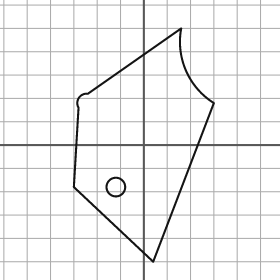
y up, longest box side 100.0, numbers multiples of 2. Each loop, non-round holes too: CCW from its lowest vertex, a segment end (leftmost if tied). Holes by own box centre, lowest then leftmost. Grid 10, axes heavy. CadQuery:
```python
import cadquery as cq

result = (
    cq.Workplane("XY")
    .moveTo(4.0, -50.0)
    .lineTo(30.0, 18.0)
    .threePointArc((18.0, 32.0), (16.0, 50.0))
    .lineTo(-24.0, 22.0)
    .threePointArc((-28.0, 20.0), (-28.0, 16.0))
    .lineTo(-30.0, -18.0)
    .close()
    .moveTo(-12.0, -18.0)
    .circle(4.0)
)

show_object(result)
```